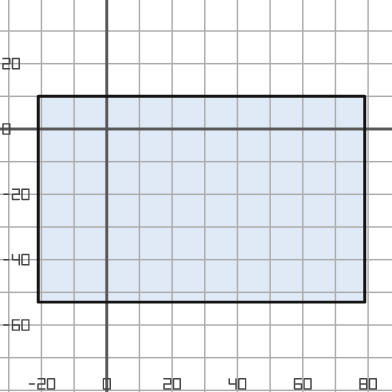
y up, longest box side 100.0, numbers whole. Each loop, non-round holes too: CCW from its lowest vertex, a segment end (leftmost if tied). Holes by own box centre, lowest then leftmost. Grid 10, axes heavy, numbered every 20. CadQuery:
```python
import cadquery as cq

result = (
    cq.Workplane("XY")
    .moveTo(-21.0, -53.0)
    .lineTo(79.0, -53.0)
    .lineTo(79.0, 10.0)
    .lineTo(-21.0, 10.0)
    .close()
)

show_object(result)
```